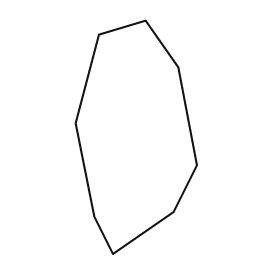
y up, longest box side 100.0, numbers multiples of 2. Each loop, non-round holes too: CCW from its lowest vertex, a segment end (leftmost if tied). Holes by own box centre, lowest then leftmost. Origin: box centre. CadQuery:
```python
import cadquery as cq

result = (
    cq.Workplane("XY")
    .moveTo(-10.0, -50.0)
    .lineTo(16.0, -32.0)
    .lineTo(26.0, -12.0)
    .lineTo(18.0, 30.0)
    .lineTo(4.0, 50.0)
    .lineTo(-16.0, 44.0)
    .lineTo(-26.0, 6.0)
    .lineTo(-18.0, -34.0)
    .close()
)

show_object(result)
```